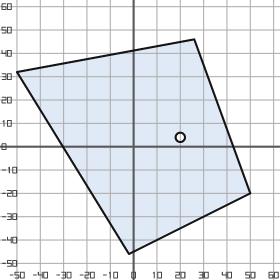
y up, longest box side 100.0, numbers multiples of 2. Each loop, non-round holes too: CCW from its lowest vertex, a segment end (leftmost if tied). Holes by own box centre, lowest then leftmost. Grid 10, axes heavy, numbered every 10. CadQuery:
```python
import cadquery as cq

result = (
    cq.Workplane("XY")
    .moveTo(-2.0, -46.0)
    .lineTo(50.0, -20.0)
    .lineTo(26.0, 46.0)
    .lineTo(-50.0, 32.0)
    .close()
    .moveTo(20.0, 4.0)
    .circle(2.0)
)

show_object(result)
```